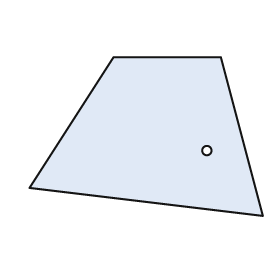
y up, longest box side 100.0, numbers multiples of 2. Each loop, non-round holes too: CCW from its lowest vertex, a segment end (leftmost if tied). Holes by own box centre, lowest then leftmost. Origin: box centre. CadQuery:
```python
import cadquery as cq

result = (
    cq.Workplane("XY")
    .moveTo(50.0, -34.0)
    .lineTo(32.0, 34.0)
    .lineTo(-14.0, 34.0)
    .lineTo(-50.0, -22.0)
    .close()
    .moveTo(26.0, -6.0)
    .circle(2.0)
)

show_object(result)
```